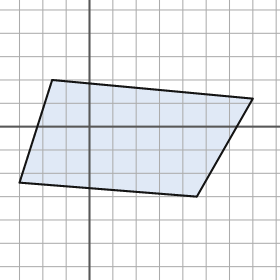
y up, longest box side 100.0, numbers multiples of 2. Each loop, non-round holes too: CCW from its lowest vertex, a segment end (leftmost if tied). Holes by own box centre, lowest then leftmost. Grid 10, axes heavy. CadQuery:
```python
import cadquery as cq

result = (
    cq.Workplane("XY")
    .moveTo(46.0, -30.0)
    .lineTo(70.0, 12.0)
    .lineTo(-16.0, 20.0)
    .lineTo(-30.0, -24.0)
    .close()
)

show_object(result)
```